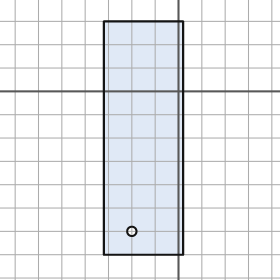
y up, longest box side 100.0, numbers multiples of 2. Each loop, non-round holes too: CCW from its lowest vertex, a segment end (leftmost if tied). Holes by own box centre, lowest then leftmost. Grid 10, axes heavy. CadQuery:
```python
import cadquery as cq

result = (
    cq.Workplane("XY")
    .moveTo(-32.0, -70.0)
    .lineTo(2.0, -70.0)
    .lineTo(2.0, 30.0)
    .lineTo(-32.0, 30.0)
    .close()
    .moveTo(-20.0, -60.0)
    .circle(2.0)
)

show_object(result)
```